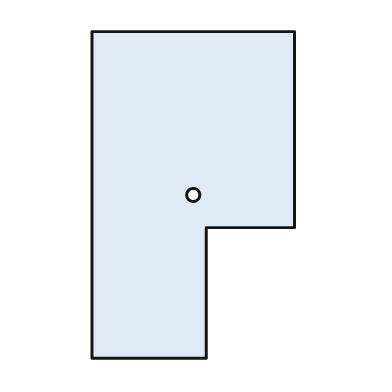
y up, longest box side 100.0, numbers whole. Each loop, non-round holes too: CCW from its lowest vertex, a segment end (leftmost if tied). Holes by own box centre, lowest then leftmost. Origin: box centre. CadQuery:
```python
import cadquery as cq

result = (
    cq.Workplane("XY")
    .moveTo(-31.0, -50.0)
    .lineTo(4.0, -50.0)
    .lineTo(4.0, -10.0)
    .lineTo(31.0, -10.0)
    .lineTo(31.0, 50.0)
    .lineTo(-31.0, 50.0)
    .close()
    .moveTo(0.0, 0.0)
    .circle(2.0)
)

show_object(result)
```